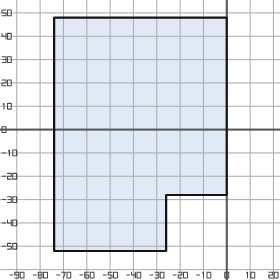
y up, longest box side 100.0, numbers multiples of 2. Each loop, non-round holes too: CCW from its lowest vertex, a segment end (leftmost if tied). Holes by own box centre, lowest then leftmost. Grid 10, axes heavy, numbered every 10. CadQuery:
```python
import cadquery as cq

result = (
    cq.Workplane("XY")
    .moveTo(-74.0, -52.0)
    .lineTo(-26.0, -52.0)
    .lineTo(-26.0, -28.0)
    .lineTo(0.0, -28.0)
    .lineTo(0.0, 48.0)
    .lineTo(-74.0, 48.0)
    .close()
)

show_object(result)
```